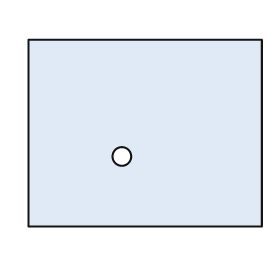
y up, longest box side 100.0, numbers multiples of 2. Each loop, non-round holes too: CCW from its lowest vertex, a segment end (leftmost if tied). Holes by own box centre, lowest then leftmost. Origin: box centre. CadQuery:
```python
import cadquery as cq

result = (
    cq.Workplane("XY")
    .moveTo(-50.0, -40.0)
    .lineTo(50.0, -40.0)
    .lineTo(50.0, 40.0)
    .lineTo(-50.0, 40.0)
    .close()
    .moveTo(-10.0, -10.0)
    .circle(4.0)
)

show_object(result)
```